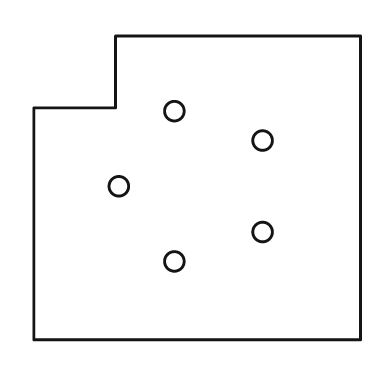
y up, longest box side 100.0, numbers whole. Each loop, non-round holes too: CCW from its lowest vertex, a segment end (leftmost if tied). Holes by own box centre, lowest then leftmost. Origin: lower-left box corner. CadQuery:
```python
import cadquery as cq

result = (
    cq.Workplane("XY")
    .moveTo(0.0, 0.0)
    .lineTo(100.0, 0.0)
    .lineTo(100.0, 93.0)
    .lineTo(25.0, 93.0)
    .lineTo(25.0, 71.0)
    .lineTo(0.0, 71.0)
    .close()
    .moveTo(43.0, 24.0)
    .circle(3.0)
    .moveTo(70.0, 33.0)
    .circle(3.0)
    .moveTo(26.0, 47.0)
    .circle(3.0)
    .moveTo(70.0, 61.0)
    .circle(3.0)
    .moveTo(43.0, 70.0)
    .circle(3.0)
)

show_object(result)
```